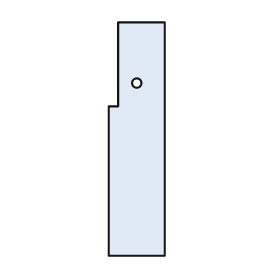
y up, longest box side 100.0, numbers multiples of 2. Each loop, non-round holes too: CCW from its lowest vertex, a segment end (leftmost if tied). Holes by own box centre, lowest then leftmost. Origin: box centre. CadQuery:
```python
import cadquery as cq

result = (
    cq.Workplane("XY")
    .moveTo(-12.0, -50.0)
    .lineTo(12.0, -50.0)
    .lineTo(12.0, 50.0)
    .lineTo(-8.0, 50.0)
    .lineTo(-8.0, 14.0)
    .lineTo(-12.0, 14.0)
    .close()
    .moveTo(0.0, 24.0)
    .circle(2.0)
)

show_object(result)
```